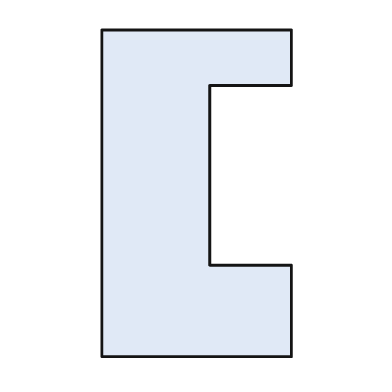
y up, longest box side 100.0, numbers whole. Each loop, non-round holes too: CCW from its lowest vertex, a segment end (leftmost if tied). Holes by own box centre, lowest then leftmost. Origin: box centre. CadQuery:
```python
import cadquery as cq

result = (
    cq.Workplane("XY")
    .moveTo(-29.0, -50.0)
    .lineTo(29.0, -50.0)
    .lineTo(29.0, -22.0)
    .lineTo(4.0, -22.0)
    .lineTo(4.0, 33.0)
    .lineTo(29.0, 33.0)
    .lineTo(29.0, 50.0)
    .lineTo(-29.0, 50.0)
    .close()
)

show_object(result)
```